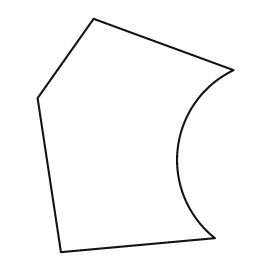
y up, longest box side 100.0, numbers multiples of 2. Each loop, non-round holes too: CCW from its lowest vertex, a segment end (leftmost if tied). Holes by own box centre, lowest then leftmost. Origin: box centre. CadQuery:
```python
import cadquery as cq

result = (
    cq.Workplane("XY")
    .moveTo(-32.0, -50.0)
    .lineTo(34.0, -44.0)
    .threePointArc((18.0, -6.0), (42.0, 28.0))
    .lineTo(-18.0, 50.0)
    .lineTo(-42.0, 16.0)
    .close()
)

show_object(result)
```